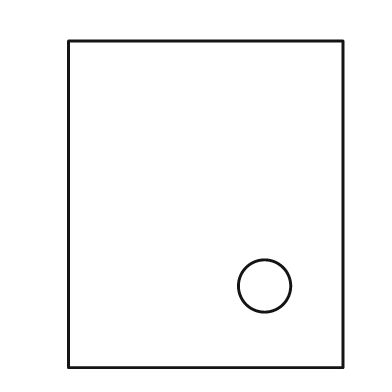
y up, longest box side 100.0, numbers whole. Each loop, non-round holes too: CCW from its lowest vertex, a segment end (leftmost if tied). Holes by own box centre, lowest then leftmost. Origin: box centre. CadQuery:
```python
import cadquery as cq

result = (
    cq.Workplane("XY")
    .moveTo(-42.0, -50.0)
    .lineTo(42.0, -50.0)
    .lineTo(42.0, 50.0)
    .lineTo(-42.0, 50.0)
    .close()
    .moveTo(18.0, -25.0)
    .circle(8.0)
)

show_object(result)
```